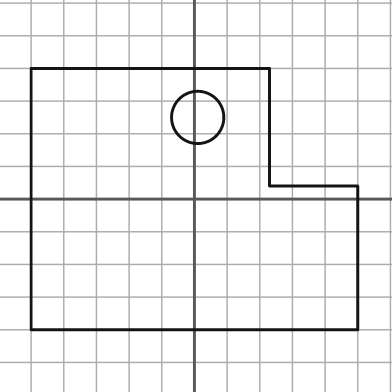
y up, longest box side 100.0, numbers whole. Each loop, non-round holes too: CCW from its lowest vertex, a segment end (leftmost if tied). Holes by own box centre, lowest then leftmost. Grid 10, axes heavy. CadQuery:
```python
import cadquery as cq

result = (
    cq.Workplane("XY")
    .moveTo(-50.0, -40.0)
    .lineTo(50.0, -40.0)
    .lineTo(50.0, 4.0)
    .lineTo(23.0, 4.0)
    .lineTo(23.0, 40.0)
    .lineTo(-50.0, 40.0)
    .close()
    .moveTo(1.0, 25.0)
    .circle(8.0)
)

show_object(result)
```